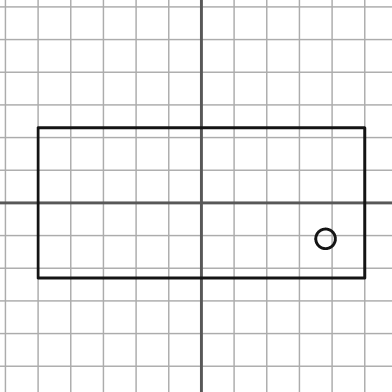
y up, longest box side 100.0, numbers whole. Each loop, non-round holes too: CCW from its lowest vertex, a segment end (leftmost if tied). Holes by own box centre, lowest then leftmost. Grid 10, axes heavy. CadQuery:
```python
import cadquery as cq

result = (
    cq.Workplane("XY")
    .moveTo(-50.0, -23.0)
    .lineTo(50.0, -23.0)
    .lineTo(50.0, 23.0)
    .lineTo(-50.0, 23.0)
    .close()
    .moveTo(38.0, -11.0)
    .circle(3.0)
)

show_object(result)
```